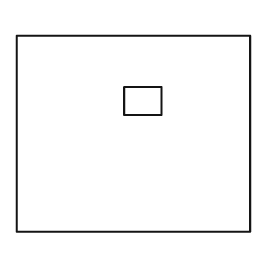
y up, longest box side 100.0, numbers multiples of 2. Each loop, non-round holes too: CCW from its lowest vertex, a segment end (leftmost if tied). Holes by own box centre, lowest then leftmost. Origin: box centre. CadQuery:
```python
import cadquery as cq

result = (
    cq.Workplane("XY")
    .moveTo(-50.0, -42.0)
    .lineTo(50.0, -42.0)
    .lineTo(50.0, 42.0)
    .lineTo(-50.0, 42.0)
    .close()
    .moveTo(-4.0, 8.0)
    .lineTo(12.0, 8.0)
    .lineTo(12.0, 20.0)
    .lineTo(-4.0, 20.0)
    .close()
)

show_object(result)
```